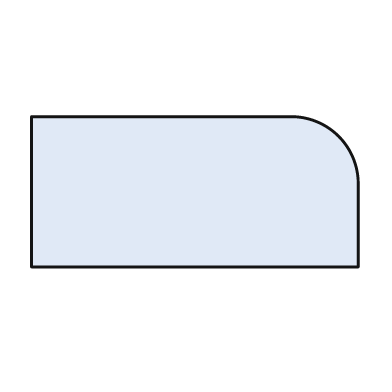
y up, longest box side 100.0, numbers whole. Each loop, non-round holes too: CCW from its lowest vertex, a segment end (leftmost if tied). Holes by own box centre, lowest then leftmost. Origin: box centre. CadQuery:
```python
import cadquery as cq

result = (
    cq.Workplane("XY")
    .moveTo(-50.0, -23.0)
    .lineTo(50.0, -23.0)
    .lineTo(50.0, 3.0)
    .threePointArc((44.0, 17.0), (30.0, 23.0))
    .lineTo(-50.0, 23.0)
    .close()
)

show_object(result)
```